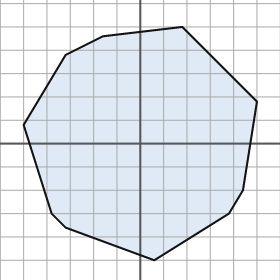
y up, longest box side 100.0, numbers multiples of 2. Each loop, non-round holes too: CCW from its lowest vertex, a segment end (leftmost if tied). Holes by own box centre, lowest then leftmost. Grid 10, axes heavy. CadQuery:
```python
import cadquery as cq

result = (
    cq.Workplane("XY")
    .moveTo(6.0, -50.0)
    .lineTo(38.0, -30.0)
    .lineTo(44.0, -20.0)
    .lineTo(50.0, 18.0)
    .lineTo(18.0, 50.0)
    .lineTo(-16.0, 46.0)
    .lineTo(-32.0, 38.0)
    .lineTo(-50.0, 8.0)
    .lineTo(-38.0, -30.0)
    .lineTo(-32.0, -36.0)
    .close()
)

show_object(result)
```